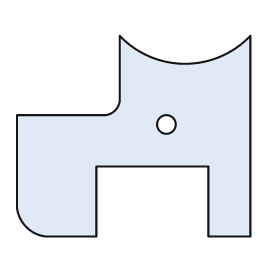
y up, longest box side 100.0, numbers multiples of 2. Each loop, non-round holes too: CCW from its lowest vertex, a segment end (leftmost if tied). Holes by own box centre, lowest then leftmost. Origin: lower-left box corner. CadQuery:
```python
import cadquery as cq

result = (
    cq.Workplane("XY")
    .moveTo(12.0, 0.0)
    .lineTo(34.0, 0.0)
    .lineTo(34.0, 30.0)
    .lineTo(82.0, 30.0)
    .lineTo(82.0, 0.0)
    .lineTo(100.0, 0.0)
    .lineTo(100.0, 86.0)
    .threePointArc((72.0, 74.0), (44.0, 86.0))
    .lineTo(44.0, 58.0)
    .threePointArc((42.0, 54.0), (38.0, 52.0))
    .lineTo(0.0, 52.0)
    .lineTo(0.0, 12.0)
    .threePointArc((4.0, 4.0), (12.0, 0.0))
    .close()
    .moveTo(64.0, 48.0)
    .circle(4.0)
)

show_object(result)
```